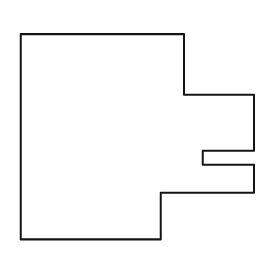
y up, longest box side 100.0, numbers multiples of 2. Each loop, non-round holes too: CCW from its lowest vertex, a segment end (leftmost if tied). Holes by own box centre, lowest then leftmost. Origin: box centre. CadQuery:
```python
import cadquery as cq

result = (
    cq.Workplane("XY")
    .moveTo(-50.0, -44.0)
    .lineTo(10.0, -44.0)
    .lineTo(10.0, -24.0)
    .lineTo(50.0, -24.0)
    .lineTo(50.0, -12.0)
    .lineTo(28.0, -12.0)
    .lineTo(28.0, -6.0)
    .lineTo(50.0, -6.0)
    .lineTo(50.0, 18.0)
    .lineTo(20.0, 18.0)
    .lineTo(20.0, 44.0)
    .lineTo(-50.0, 44.0)
    .close()
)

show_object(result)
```